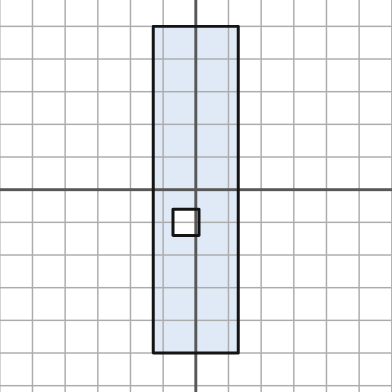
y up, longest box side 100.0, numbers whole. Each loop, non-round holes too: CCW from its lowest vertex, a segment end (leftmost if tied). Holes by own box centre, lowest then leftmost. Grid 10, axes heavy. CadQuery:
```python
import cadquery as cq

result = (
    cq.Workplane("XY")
    .moveTo(-13.0, -50.0)
    .lineTo(13.0, -50.0)
    .lineTo(13.0, 50.0)
    .lineTo(-13.0, 50.0)
    .close()
    .moveTo(-7.0, -14.0)
    .lineTo(1.0, -14.0)
    .lineTo(1.0, -6.0)
    .lineTo(-7.0, -6.0)
    .close()
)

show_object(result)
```